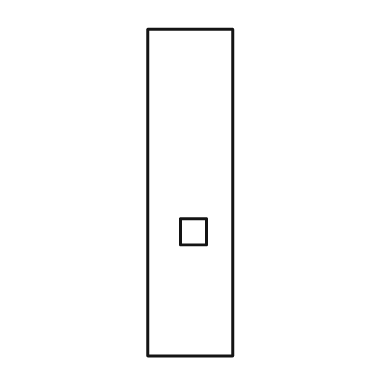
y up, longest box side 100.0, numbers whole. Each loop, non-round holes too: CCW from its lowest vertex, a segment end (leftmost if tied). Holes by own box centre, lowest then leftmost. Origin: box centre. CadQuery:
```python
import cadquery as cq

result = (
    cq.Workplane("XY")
    .moveTo(-13.0, -50.0)
    .lineTo(13.0, -50.0)
    .lineTo(13.0, 50.0)
    .lineTo(-13.0, 50.0)
    .close()
    .moveTo(-3.0, -16.0)
    .lineTo(5.0, -16.0)
    .lineTo(5.0, -8.0)
    .lineTo(-3.0, -8.0)
    .close()
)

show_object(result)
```